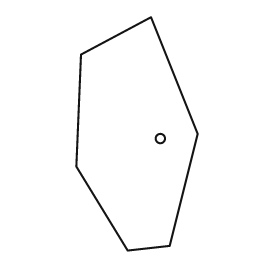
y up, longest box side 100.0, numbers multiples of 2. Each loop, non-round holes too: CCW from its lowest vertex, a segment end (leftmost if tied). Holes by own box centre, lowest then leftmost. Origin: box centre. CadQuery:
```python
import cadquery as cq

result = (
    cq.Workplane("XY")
    .moveTo(-4.0, -50.0)
    .lineTo(14.0, -48.0)
    .lineTo(26.0, 0.0)
    .lineTo(6.0, 50.0)
    .lineTo(-24.0, 34.0)
    .lineTo(-26.0, -14.0)
    .close()
    .moveTo(10.0, -2.0)
    .circle(2.0)
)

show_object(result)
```